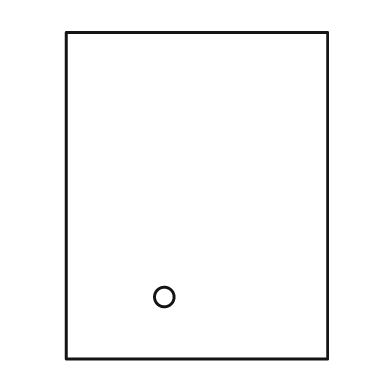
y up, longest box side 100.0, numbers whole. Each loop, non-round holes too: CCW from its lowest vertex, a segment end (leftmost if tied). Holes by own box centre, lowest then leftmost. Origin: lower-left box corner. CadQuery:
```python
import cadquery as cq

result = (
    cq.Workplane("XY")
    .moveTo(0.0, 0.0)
    .lineTo(80.0, 0.0)
    .lineTo(80.0, 100.0)
    .lineTo(0.0, 100.0)
    .close()
    .moveTo(30.0, 19.0)
    .circle(3.0)
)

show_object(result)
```